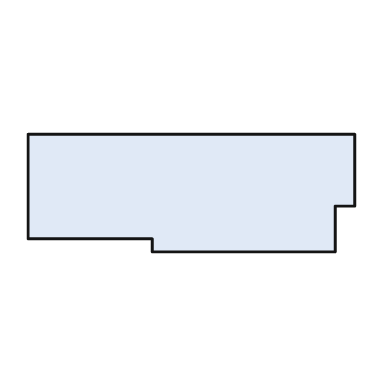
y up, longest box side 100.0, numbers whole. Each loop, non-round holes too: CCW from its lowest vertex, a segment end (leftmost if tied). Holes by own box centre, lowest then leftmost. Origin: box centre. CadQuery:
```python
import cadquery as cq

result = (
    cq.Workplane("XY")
    .moveTo(-12.0, -18.0)
    .lineTo(44.0, -18.0)
    .lineTo(44.0, -4.0)
    .lineTo(50.0, -4.0)
    .lineTo(50.0, 18.0)
    .lineTo(-50.0, 18.0)
    .lineTo(-50.0, -14.0)
    .lineTo(-12.0, -14.0)
    .close()
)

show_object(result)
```